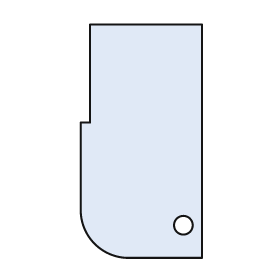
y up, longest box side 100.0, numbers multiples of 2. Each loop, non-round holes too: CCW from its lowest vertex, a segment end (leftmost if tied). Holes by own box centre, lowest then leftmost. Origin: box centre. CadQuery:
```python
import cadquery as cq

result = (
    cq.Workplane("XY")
    .moveTo(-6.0, -50.0)
    .lineTo(26.0, -50.0)
    .lineTo(26.0, 50.0)
    .lineTo(-22.0, 50.0)
    .lineTo(-22.0, 8.0)
    .lineTo(-26.0, 8.0)
    .lineTo(-26.0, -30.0)
    .threePointArc((-20.0, -44.0), (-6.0, -50.0))
    .close()
    .moveTo(18.0, -36.0)
    .circle(4.0)
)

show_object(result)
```